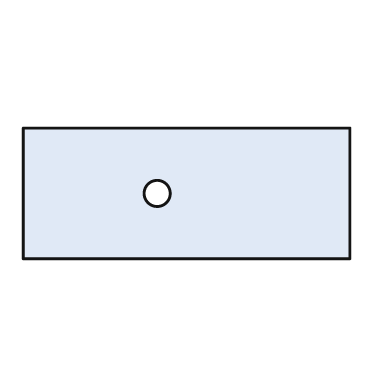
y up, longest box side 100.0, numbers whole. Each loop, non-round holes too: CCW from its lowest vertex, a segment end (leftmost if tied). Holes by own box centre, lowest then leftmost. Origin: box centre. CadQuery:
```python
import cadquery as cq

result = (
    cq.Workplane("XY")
    .moveTo(-50.0, -20.0)
    .lineTo(50.0, -20.0)
    .lineTo(50.0, 20.0)
    .lineTo(-50.0, 20.0)
    .close()
    .moveTo(-9.0, 0.0)
    .circle(4.0)
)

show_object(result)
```